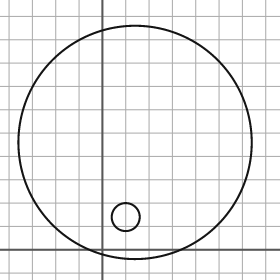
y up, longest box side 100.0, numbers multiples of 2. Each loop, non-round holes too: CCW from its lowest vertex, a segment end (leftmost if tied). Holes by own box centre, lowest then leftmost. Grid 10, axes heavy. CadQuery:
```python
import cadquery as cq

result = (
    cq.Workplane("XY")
    .moveTo(14.0, 46.0)
    .circle(50.0)
    .moveTo(10.0, 14.0)
    .circle(6.0)
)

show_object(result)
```